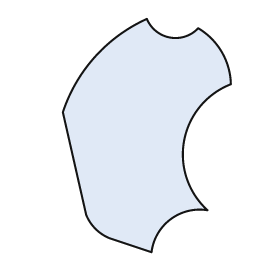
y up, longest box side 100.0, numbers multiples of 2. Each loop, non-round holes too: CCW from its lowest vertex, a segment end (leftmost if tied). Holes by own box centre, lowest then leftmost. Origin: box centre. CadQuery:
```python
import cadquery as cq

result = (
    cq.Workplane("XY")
    .moveTo(2.0, -50.0)
    .threePointArc((10.0, -36.0), (26.0, -32.0))
    .threePointArc((16.0, -2.0), (36.0, 22.0))
    .threePointArc((32.0, 36.0), (22.0, 46.0))
    .threePointArc((10.0, 42.0), (0.0, 50.0))
    .threePointArc((-22.0, 34.0), (-36.0, 10.0))
    .lineTo(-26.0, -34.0)
    .threePointArc((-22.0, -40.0), (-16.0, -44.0))
    .close()
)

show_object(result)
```